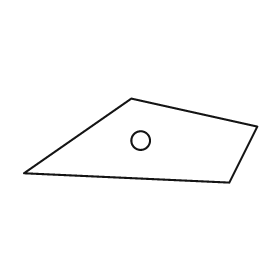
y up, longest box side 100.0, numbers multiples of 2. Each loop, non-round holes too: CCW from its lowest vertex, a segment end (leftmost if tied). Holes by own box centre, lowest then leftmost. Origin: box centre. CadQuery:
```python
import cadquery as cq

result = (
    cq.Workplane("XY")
    .moveTo(38.0, -18.0)
    .lineTo(50.0, 6.0)
    .lineTo(-4.0, 18.0)
    .lineTo(-50.0, -14.0)
    .close()
    .moveTo(0.0, 0.0)
    .circle(4.0)
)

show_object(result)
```